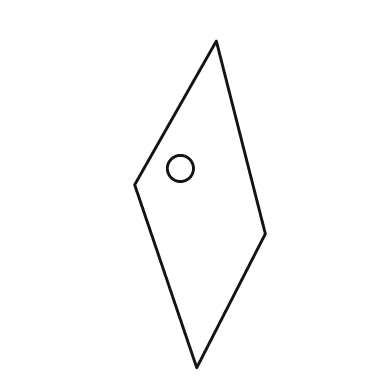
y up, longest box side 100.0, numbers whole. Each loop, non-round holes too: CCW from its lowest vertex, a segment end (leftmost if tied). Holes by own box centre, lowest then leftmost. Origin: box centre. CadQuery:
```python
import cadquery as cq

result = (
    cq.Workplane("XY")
    .moveTo(-1.0, -50.0)
    .lineTo(20.0, -9.0)
    .lineTo(5.0, 50.0)
    .lineTo(-20.0, 6.0)
    .close()
    .moveTo(-6.0, 11.0)
    .circle(4.0)
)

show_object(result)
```